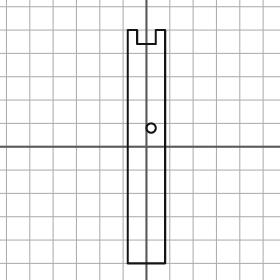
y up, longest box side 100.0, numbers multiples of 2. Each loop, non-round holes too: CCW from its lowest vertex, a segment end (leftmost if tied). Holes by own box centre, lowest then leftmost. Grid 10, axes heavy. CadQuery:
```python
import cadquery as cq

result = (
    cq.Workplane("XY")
    .moveTo(-8.0, -50.0)
    .lineTo(8.0, -50.0)
    .lineTo(8.0, 50.0)
    .lineTo(4.0, 50.0)
    .lineTo(4.0, 44.0)
    .lineTo(-4.0, 44.0)
    .lineTo(-4.0, 50.0)
    .lineTo(-8.0, 50.0)
    .close()
    .moveTo(2.0, 8.0)
    .circle(2.0)
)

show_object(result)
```